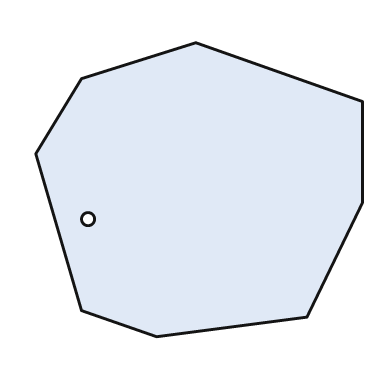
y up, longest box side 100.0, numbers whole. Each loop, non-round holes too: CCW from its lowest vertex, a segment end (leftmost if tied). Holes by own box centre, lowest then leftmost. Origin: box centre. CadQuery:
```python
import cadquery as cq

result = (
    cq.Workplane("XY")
    .moveTo(-13.0, -45.0)
    .lineTo(33.0, -39.0)
    .lineTo(50.0, -4.0)
    .lineTo(50.0, 27.0)
    .lineTo(-1.0, 45.0)
    .lineTo(-36.0, 34.0)
    .lineTo(-50.0, 11.0)
    .lineTo(-36.0, -37.0)
    .close()
    .moveTo(-34.0, -9.0)
    .circle(2.0)
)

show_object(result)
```